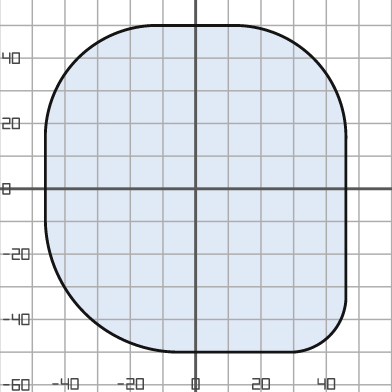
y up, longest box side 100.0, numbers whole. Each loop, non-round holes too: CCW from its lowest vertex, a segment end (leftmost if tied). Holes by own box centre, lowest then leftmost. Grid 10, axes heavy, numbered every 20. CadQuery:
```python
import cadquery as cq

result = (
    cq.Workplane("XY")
    .moveTo(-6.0, -50.0)
    .lineTo(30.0, -50.0)
    .threePointArc((41.0, -45.0), (46.0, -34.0))
    .lineTo(46.0, 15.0)
    .threePointArc((36.0, 40.0), (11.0, 50.0))
    .lineTo(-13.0, 50.0)
    .threePointArc((-36.0, 40.0), (-46.0, 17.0))
    .lineTo(-46.0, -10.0)
    .threePointArc((-34.0, -38.0), (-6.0, -50.0))
    .close()
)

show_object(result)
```